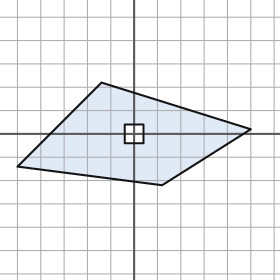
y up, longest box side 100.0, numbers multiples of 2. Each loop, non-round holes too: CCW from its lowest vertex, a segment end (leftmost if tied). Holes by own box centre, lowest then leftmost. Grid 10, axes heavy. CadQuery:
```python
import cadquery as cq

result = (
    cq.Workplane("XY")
    .moveTo(12.0, -22.0)
    .lineTo(50.0, 2.0)
    .lineTo(-14.0, 22.0)
    .lineTo(-50.0, -14.0)
    .close()
    .moveTo(-4.0, -4.0)
    .lineTo(4.0, -4.0)
    .lineTo(4.0, 4.0)
    .lineTo(-4.0, 4.0)
    .close()
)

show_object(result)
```